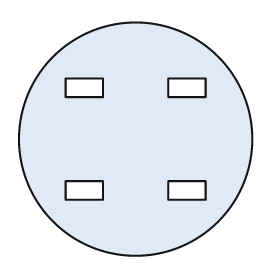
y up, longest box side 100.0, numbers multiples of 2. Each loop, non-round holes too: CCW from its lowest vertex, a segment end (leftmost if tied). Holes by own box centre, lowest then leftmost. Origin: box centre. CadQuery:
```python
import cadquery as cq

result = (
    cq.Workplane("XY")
    .moveTo(0.0, 0.0)
    .circle(50.0)
    .moveTo(-30.0, -26.0)
    .lineTo(-14.0, -26.0)
    .lineTo(-14.0, -18.0)
    .lineTo(-30.0, -18.0)
    .close()
    .moveTo(14.0, -26.0)
    .lineTo(30.0, -26.0)
    .lineTo(30.0, -18.0)
    .lineTo(14.0, -18.0)
    .close()
    .moveTo(-30.0, 18.0)
    .lineTo(-14.0, 18.0)
    .lineTo(-14.0, 26.0)
    .lineTo(-30.0, 26.0)
    .close()
    .moveTo(14.0, 18.0)
    .lineTo(30.0, 18.0)
    .lineTo(30.0, 26.0)
    .lineTo(14.0, 26.0)
    .close()
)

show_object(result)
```